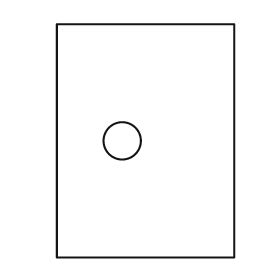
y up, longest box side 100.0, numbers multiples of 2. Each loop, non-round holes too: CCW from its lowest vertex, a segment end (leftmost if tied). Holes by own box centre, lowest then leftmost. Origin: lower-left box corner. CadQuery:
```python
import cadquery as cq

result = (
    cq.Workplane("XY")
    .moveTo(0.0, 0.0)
    .lineTo(76.0, 0.0)
    .lineTo(76.0, 100.0)
    .lineTo(0.0, 100.0)
    .close()
    .moveTo(28.0, 50.0)
    .circle(8.0)
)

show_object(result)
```